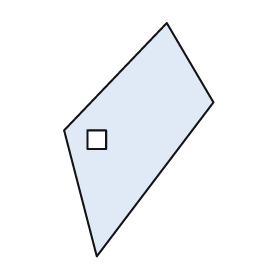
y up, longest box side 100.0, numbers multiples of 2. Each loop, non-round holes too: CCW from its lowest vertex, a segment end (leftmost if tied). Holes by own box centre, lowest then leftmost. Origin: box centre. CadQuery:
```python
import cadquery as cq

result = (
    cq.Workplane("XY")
    .moveTo(-18.0, -50.0)
    .lineTo(32.0, 16.0)
    .lineTo(12.0, 50.0)
    .lineTo(-32.0, 4.0)
    .close()
    .moveTo(-22.0, -4.0)
    .lineTo(-14.0, -4.0)
    .lineTo(-14.0, 4.0)
    .lineTo(-22.0, 4.0)
    .close()
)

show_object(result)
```